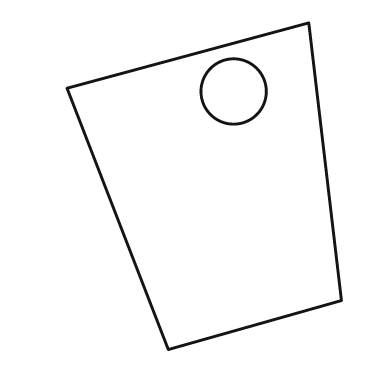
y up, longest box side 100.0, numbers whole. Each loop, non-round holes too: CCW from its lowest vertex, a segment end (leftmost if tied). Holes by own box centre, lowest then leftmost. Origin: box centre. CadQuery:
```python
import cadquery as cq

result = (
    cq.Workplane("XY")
    .moveTo(-11.0, -50.0)
    .lineTo(42.0, -35.0)
    .lineTo(32.0, 50.0)
    .lineTo(-42.0, 30.0)
    .close()
    .moveTo(9.0, 29.0)
    .circle(10.0)
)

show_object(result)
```